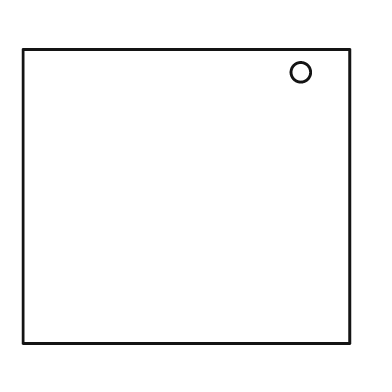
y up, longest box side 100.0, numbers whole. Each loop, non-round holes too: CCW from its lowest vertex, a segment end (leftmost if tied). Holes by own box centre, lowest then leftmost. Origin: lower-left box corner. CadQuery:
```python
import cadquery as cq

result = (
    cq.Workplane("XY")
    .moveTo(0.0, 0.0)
    .lineTo(100.0, 0.0)
    .lineTo(100.0, 90.0)
    .lineTo(0.0, 90.0)
    .close()
    .moveTo(85.0, 83.0)
    .circle(3.0)
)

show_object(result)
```